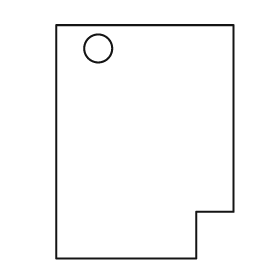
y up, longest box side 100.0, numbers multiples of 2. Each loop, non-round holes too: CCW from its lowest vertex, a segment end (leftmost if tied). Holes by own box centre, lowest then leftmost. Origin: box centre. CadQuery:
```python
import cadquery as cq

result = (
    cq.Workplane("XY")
    .moveTo(-38.0, -50.0)
    .lineTo(22.0, -50.0)
    .lineTo(22.0, -30.0)
    .lineTo(38.0, -30.0)
    .lineTo(38.0, 50.0)
    .lineTo(-38.0, 50.0)
    .close()
    .moveTo(-20.0, 40.0)
    .circle(6.0)
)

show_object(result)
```